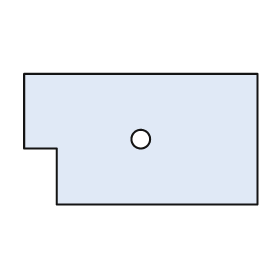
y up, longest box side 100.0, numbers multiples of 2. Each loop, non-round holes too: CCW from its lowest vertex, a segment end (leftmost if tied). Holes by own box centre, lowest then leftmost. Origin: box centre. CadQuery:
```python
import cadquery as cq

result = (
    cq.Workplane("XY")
    .moveTo(-36.0, -28.0)
    .lineTo(50.0, -28.0)
    .lineTo(50.0, 28.0)
    .lineTo(-50.0, 28.0)
    .lineTo(-50.0, -4.0)
    .lineTo(-36.0, -4.0)
    .close()
    .moveTo(0.0, 0.0)
    .circle(4.0)
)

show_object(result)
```